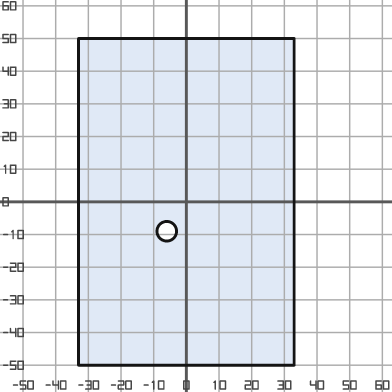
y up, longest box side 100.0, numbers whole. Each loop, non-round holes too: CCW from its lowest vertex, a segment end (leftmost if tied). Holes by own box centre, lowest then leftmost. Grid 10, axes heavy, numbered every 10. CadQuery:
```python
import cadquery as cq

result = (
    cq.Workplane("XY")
    .moveTo(-33.0, -50.0)
    .lineTo(33.0, -50.0)
    .lineTo(33.0, 50.0)
    .lineTo(-33.0, 50.0)
    .close()
    .moveTo(-6.0, -9.0)
    .circle(3.0)
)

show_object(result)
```